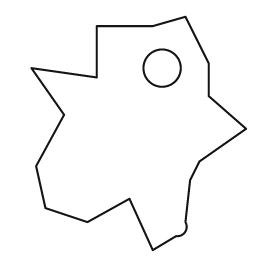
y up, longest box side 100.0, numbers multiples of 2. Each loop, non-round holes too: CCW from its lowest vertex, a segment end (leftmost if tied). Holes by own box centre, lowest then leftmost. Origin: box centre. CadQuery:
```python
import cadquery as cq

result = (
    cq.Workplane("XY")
    .moveTo(6.0, -50.0)
    .lineTo(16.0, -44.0)
    .threePointArc((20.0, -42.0), (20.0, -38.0))
    .lineTo(22.0, -20.0)
    .lineTo(26.0, -12.0)
    .lineTo(46.0, 2.0)
    .lineTo(30.0, 16.0)
    .lineTo(30.0, 30.0)
    .lineTo(20.0, 50.0)
    .lineTo(6.0, 46.0)
    .lineTo(-18.0, 46.0)
    .lineTo(-18.0, 24.0)
    .lineTo(-46.0, 28.0)
    .lineTo(-32.0, 8.0)
    .lineTo(-44.0, -14.0)
    .lineTo(-40.0, -32.0)
    .lineTo(-22.0, -38.0)
    .lineTo(-4.0, -28.0)
    .close()
    .moveTo(10.0, 28.0)
    .circle(8.0)
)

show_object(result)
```